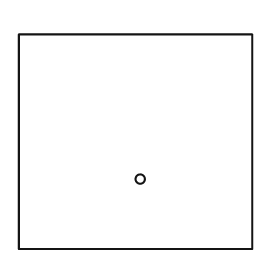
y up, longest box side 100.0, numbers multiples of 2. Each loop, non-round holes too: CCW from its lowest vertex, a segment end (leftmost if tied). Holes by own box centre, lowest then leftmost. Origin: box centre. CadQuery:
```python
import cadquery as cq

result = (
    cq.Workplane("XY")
    .moveTo(-50.0, -46.0)
    .lineTo(50.0, -46.0)
    .lineTo(50.0, 46.0)
    .lineTo(-50.0, 46.0)
    .close()
    .moveTo(2.0, -16.0)
    .circle(2.0)
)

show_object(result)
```